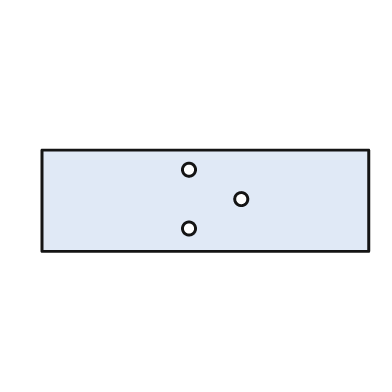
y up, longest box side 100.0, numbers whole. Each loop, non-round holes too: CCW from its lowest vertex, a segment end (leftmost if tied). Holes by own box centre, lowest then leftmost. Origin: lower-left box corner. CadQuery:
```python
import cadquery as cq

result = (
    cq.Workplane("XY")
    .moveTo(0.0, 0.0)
    .lineTo(100.0, 0.0)
    .lineTo(100.0, 31.0)
    .lineTo(0.0, 31.0)
    .close()
    .moveTo(45.0, 7.0)
    .circle(2.0)
    .moveTo(61.0, 16.0)
    .circle(2.0)
    .moveTo(45.0, 25.0)
    .circle(2.0)
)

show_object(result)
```